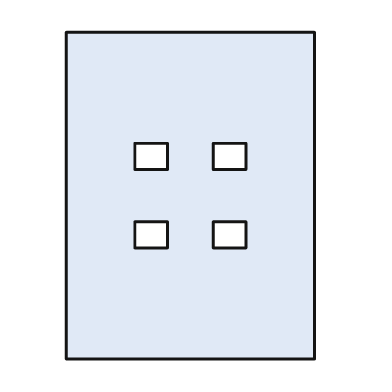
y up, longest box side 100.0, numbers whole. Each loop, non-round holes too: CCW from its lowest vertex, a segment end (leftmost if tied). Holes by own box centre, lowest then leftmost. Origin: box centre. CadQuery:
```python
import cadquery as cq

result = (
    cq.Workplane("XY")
    .moveTo(-38.0, -50.0)
    .lineTo(38.0, -50.0)
    .lineTo(38.0, 50.0)
    .lineTo(-38.0, 50.0)
    .close()
    .moveTo(-17.0, -16.0)
    .lineTo(-7.0, -16.0)
    .lineTo(-7.0, -8.0)
    .lineTo(-17.0, -8.0)
    .close()
    .moveTo(7.0, -16.0)
    .lineTo(17.0, -16.0)
    .lineTo(17.0, -8.0)
    .lineTo(7.0, -8.0)
    .close()
    .moveTo(-17.0, 8.0)
    .lineTo(-7.0, 8.0)
    .lineTo(-7.0, 16.0)
    .lineTo(-17.0, 16.0)
    .close()
    .moveTo(7.0, 8.0)
    .lineTo(17.0, 8.0)
    .lineTo(17.0, 16.0)
    .lineTo(7.0, 16.0)
    .close()
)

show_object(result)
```